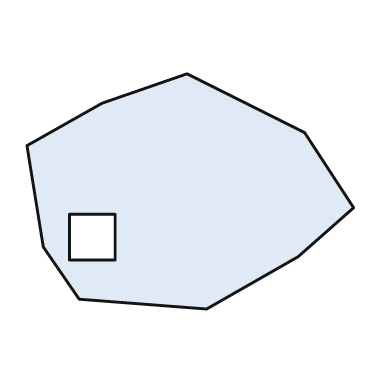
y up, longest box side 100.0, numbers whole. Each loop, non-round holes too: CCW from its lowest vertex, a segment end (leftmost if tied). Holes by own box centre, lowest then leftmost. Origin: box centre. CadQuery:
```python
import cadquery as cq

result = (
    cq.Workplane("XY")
    .moveTo(5.0, -36.0)
    .lineTo(33.0, -20.0)
    .lineTo(50.0, -5.0)
    .lineTo(35.0, 18.0)
    .lineTo(-1.0, 36.0)
    .lineTo(-27.0, 27.0)
    .lineTo(-50.0, 14.0)
    .lineTo(-45.0, -17.0)
    .lineTo(-34.0, -33.0)
    .close()
    .moveTo(-37.0, -21.0)
    .lineTo(-23.0, -21.0)
    .lineTo(-23.0, -7.0)
    .lineTo(-37.0, -7.0)
    .close()
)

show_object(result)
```